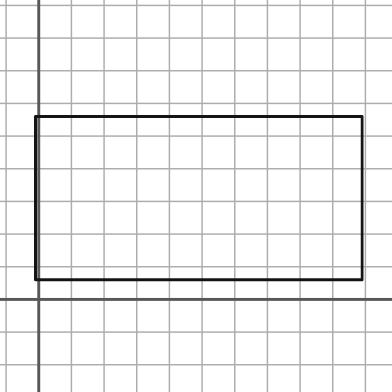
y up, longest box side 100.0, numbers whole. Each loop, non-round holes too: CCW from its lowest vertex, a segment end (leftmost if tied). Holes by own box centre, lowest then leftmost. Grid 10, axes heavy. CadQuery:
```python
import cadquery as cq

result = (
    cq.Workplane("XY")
    .moveTo(-1.0, 6.0)
    .lineTo(99.0, 6.0)
    .lineTo(99.0, 56.0)
    .lineTo(-1.0, 56.0)
    .close()
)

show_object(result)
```